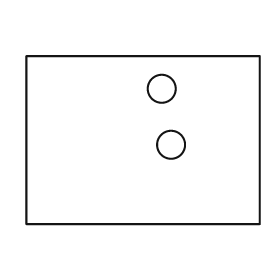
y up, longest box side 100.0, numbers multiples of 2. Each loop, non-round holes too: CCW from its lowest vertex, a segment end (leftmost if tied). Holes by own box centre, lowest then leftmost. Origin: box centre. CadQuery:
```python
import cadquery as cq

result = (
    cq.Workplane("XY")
    .moveTo(-50.0, -36.0)
    .lineTo(50.0, -36.0)
    .lineTo(50.0, 36.0)
    .lineTo(-50.0, 36.0)
    .close()
    .moveTo(12.0, -2.0)
    .circle(6.0)
    .moveTo(8.0, 22.0)
    .circle(6.0)
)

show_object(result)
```